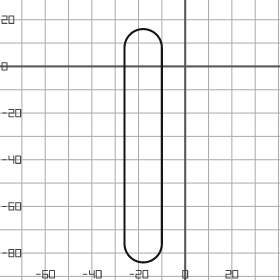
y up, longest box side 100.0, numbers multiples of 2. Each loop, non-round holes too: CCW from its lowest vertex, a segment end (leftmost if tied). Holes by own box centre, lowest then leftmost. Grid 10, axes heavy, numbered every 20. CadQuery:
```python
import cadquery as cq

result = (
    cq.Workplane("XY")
    .moveTo(-26.0, -76.0)
    .threePointArc((-18.0, -84.0), (-10.0, -76.0))
    .lineTo(-10.0, 8.0)
    .threePointArc((-18.0, 16.0), (-26.0, 8.0))
    .close()
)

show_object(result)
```